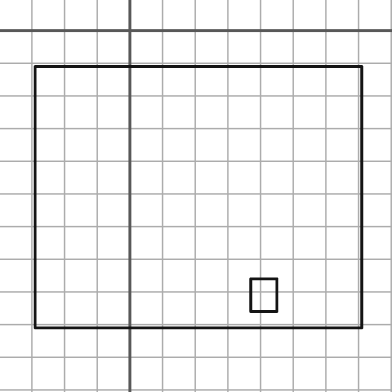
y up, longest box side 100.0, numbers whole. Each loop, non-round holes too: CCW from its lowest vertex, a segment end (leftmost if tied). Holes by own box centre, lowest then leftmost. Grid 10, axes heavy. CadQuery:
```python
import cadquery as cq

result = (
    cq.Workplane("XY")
    .moveTo(-29.0, -91.0)
    .lineTo(71.0, -91.0)
    .lineTo(71.0, -11.0)
    .lineTo(-29.0, -11.0)
    .close()
    .moveTo(37.0, -86.0)
    .lineTo(45.0, -86.0)
    .lineTo(45.0, -76.0)
    .lineTo(37.0, -76.0)
    .close()
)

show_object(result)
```